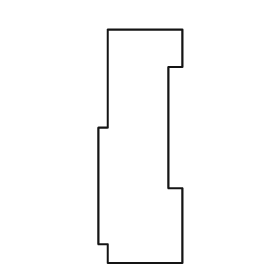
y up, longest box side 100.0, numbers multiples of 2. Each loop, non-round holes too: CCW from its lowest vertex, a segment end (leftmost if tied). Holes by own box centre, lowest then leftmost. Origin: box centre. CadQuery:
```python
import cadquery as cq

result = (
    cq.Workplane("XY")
    .moveTo(-14.0, -50.0)
    .lineTo(18.0, -50.0)
    .lineTo(18.0, -18.0)
    .lineTo(12.0, -18.0)
    .lineTo(12.0, 34.0)
    .lineTo(18.0, 34.0)
    .lineTo(18.0, 50.0)
    .lineTo(-14.0, 50.0)
    .lineTo(-14.0, 8.0)
    .lineTo(-18.0, 8.0)
    .lineTo(-18.0, -42.0)
    .lineTo(-14.0, -42.0)
    .close()
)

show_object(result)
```